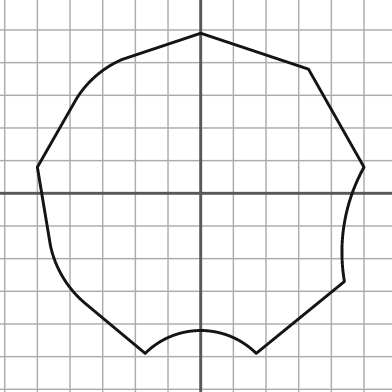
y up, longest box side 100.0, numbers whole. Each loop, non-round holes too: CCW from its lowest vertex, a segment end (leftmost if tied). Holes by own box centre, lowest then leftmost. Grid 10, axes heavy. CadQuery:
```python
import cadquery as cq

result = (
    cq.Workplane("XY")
    .moveTo(-17.0, -49.0)
    .threePointArc((0.0, -42.0), (17.0, -49.0))
    .lineTo(44.0, -27.0)
    .threePointArc((44.0, -9.0), (50.0, 8.0))
    .lineTo(33.0, 38.0)
    .lineTo(0.0, 49.0)
    .lineTo(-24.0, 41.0)
    .threePointArc((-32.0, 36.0), (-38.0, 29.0))
    .lineTo(-50.0, 8.0)
    .lineTo(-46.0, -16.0)
    .threePointArc((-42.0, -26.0), (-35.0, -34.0))
    .close()
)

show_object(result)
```